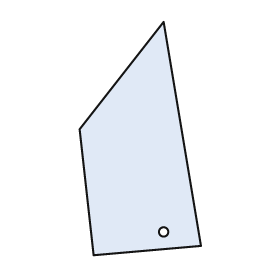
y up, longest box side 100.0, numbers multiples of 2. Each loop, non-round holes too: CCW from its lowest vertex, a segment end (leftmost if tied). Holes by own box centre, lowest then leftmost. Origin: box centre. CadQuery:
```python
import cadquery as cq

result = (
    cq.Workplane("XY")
    .moveTo(-20.0, -50.0)
    .lineTo(26.0, -46.0)
    .lineTo(10.0, 50.0)
    .lineTo(-26.0, 4.0)
    .close()
    .moveTo(10.0, -40.0)
    .circle(2.0)
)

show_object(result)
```